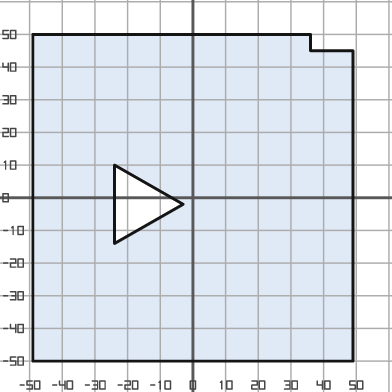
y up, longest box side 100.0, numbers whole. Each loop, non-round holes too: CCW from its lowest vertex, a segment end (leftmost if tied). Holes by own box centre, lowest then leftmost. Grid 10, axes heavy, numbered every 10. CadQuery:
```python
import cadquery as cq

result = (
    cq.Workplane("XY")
    .moveTo(-49.0, -50.0)
    .lineTo(49.0, -50.0)
    .lineTo(49.0, 45.0)
    .lineTo(36.0, 45.0)
    .lineTo(36.0, 50.0)
    .lineTo(-49.0, 50.0)
    .close()
    .moveTo(-24.0, -14.0)
    .lineTo(-3.0, -2.0)
    .lineTo(-24.0, 10.0)
    .close()
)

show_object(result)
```